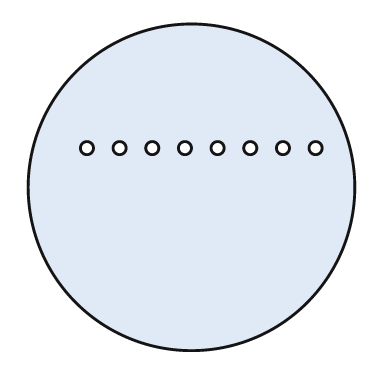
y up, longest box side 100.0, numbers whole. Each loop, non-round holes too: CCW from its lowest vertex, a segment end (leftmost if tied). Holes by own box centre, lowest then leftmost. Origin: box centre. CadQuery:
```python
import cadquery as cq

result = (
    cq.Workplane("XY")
    .moveTo(0.0, 0.0)
    .circle(50.0)
    .moveTo(-32.0, 12.0)
    .circle(2.0)
    .moveTo(-22.0, 12.0)
    .circle(2.0)
    .moveTo(-12.0, 12.0)
    .circle(2.0)
    .moveTo(-2.0, 12.0)
    .circle(2.0)
    .moveTo(8.0, 12.0)
    .circle(2.0)
    .moveTo(18.0, 12.0)
    .circle(2.0)
    .moveTo(28.0, 12.0)
    .circle(2.0)
    .moveTo(38.0, 12.0)
    .circle(2.0)
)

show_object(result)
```